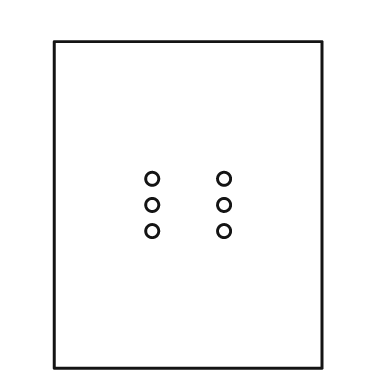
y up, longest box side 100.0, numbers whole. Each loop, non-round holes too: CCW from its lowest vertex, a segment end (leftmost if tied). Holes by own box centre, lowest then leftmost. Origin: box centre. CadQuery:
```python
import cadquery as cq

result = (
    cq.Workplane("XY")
    .moveTo(-41.0, -50.0)
    .lineTo(41.0, -50.0)
    .lineTo(41.0, 50.0)
    .lineTo(-41.0, 50.0)
    .close()
    .moveTo(-11.0, -8.0)
    .circle(2.0)
    .moveTo(11.0, -8.0)
    .circle(2.0)
    .moveTo(-11.0, 0.0)
    .circle(2.0)
    .moveTo(11.0, 0.0)
    .circle(2.0)
    .moveTo(-11.0, 8.0)
    .circle(2.0)
    .moveTo(11.0, 8.0)
    .circle(2.0)
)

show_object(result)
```